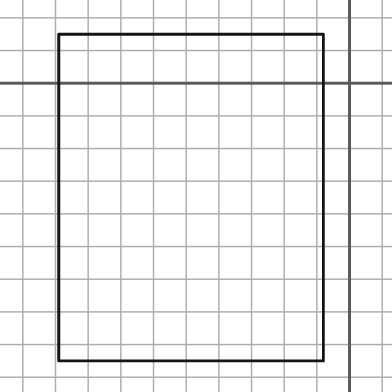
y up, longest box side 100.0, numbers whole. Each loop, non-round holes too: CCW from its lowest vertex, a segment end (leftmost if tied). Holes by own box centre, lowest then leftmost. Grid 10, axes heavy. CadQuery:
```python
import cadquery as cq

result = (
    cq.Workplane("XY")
    .moveTo(-89.0, -85.0)
    .lineTo(-8.0, -85.0)
    .lineTo(-8.0, 15.0)
    .lineTo(-89.0, 15.0)
    .close()
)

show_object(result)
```